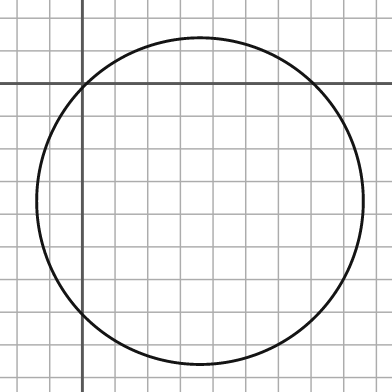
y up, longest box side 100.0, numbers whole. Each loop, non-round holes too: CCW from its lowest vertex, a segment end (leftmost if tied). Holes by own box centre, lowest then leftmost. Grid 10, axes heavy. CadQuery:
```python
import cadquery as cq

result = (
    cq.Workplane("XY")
    .moveTo(36.0, -36.0)
    .circle(50.0)
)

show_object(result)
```